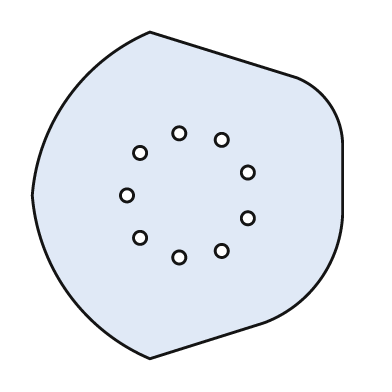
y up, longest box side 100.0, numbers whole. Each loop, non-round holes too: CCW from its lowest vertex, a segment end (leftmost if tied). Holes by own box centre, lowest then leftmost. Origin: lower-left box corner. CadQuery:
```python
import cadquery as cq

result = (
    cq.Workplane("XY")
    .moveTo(36.0, 0.0)
    .lineTo(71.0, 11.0)
    .threePointArc((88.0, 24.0), (95.0, 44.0))
    .lineTo(95.0, 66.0)
    .threePointArc((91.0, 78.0), (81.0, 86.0))
    .lineTo(36.0, 100.0)
    .threePointArc((11.0, 80.0), (0.0, 50.0))
    .threePointArc((11.0, 20.0), (36.0, 0.0))
    .close()
    .moveTo(45.0, 31.0)
    .circle(2.0)
    .moveTo(58.0, 33.0)
    .circle(2.0)
    .moveTo(33.0, 37.0)
    .circle(2.0)
    .moveTo(66.0, 43.0)
    .circle(2.0)
    .moveTo(29.0, 50.0)
    .circle(2.0)
    .moveTo(66.0, 57.0)
    .circle(2.0)
    .moveTo(33.0, 63.0)
    .circle(2.0)
    .moveTo(58.0, 67.0)
    .circle(2.0)
    .moveTo(45.0, 69.0)
    .circle(2.0)
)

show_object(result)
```